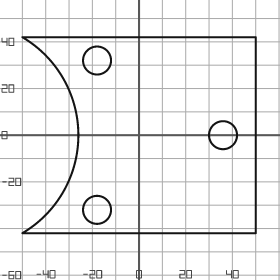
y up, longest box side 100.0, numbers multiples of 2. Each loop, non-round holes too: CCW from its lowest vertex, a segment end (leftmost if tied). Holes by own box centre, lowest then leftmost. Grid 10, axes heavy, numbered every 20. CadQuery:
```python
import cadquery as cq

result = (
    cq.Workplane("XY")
    .moveTo(-50.0, -42.0)
    .lineTo(50.0, -42.0)
    .lineTo(50.0, 42.0)
    .lineTo(-50.0, 42.0)
    .threePointArc((-26.0, 0.0), (-50.0, -42.0))
    .close()
    .moveTo(-18.0, -32.0)
    .circle(6.0)
    .moveTo(36.0, 0.0)
    .circle(6.0)
    .moveTo(-18.0, 32.0)
    .circle(6.0)
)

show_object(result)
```